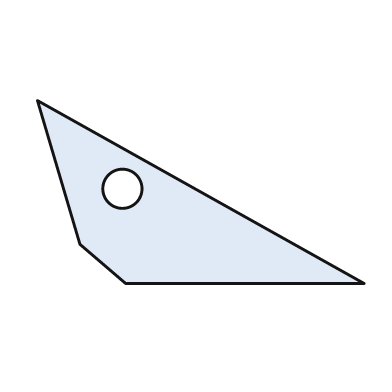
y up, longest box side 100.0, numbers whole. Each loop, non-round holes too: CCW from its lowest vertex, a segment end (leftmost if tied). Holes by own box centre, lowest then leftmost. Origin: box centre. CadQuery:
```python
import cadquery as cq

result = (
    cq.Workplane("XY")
    .moveTo(-23.0, -28.0)
    .lineTo(50.0, -28.0)
    .lineTo(-50.0, 28.0)
    .lineTo(-37.0, -16.0)
    .close()
    .moveTo(-24.0, 1.0)
    .circle(6.0)
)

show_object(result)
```